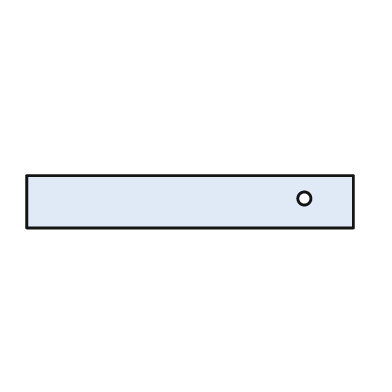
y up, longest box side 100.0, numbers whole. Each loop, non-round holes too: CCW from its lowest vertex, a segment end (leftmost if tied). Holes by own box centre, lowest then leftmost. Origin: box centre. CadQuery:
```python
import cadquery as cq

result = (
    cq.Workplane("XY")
    .moveTo(-50.0, -8.0)
    .lineTo(50.0, -8.0)
    .lineTo(50.0, 8.0)
    .lineTo(-50.0, 8.0)
    .close()
    .moveTo(35.0, 1.0)
    .circle(2.0)
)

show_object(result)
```